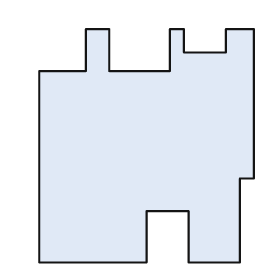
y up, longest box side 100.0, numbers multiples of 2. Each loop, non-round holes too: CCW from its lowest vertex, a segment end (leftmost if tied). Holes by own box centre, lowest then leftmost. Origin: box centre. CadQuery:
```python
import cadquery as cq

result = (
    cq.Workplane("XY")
    .moveTo(-46.0, -50.0)
    .lineTo(0.0, -50.0)
    .lineTo(0.0, -28.0)
    .lineTo(18.0, -28.0)
    .lineTo(18.0, -50.0)
    .lineTo(40.0, -50.0)
    .lineTo(40.0, -14.0)
    .lineTo(46.0, -14.0)
    .lineTo(46.0, 50.0)
    .lineTo(34.0, 50.0)
    .lineTo(34.0, 40.0)
    .lineTo(16.0, 40.0)
    .lineTo(16.0, 50.0)
    .lineTo(10.0, 50.0)
    .lineTo(10.0, 32.0)
    .lineTo(-16.0, 32.0)
    .lineTo(-16.0, 50.0)
    .lineTo(-26.0, 50.0)
    .lineTo(-26.0, 32.0)
    .lineTo(-46.0, 32.0)
    .close()
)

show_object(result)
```